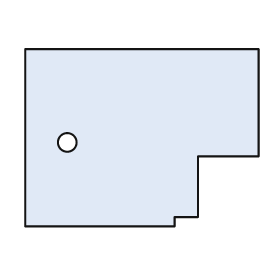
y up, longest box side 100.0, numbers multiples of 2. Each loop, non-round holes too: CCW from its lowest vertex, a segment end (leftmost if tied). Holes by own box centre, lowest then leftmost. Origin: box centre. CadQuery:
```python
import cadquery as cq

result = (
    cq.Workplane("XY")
    .moveTo(-50.0, -38.0)
    .lineTo(14.0, -38.0)
    .lineTo(14.0, -34.0)
    .lineTo(24.0, -34.0)
    .lineTo(24.0, -8.0)
    .lineTo(50.0, -8.0)
    .lineTo(50.0, 38.0)
    .lineTo(-50.0, 38.0)
    .close()
    .moveTo(-32.0, -2.0)
    .circle(4.0)
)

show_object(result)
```